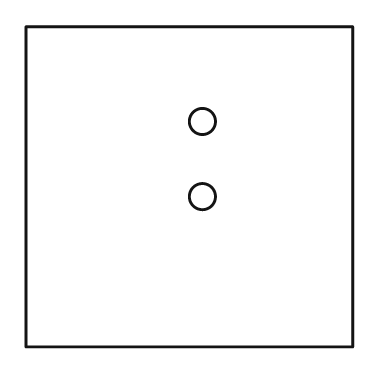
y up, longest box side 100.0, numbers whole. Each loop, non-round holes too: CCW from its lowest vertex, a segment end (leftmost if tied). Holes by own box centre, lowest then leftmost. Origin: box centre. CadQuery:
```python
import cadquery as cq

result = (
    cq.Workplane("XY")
    .moveTo(-50.0, -49.0)
    .lineTo(50.0, -49.0)
    .lineTo(50.0, 49.0)
    .lineTo(-50.0, 49.0)
    .close()
    .moveTo(4.0, -3.0)
    .circle(4.0)
    .moveTo(4.0, 20.0)
    .circle(4.0)
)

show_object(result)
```